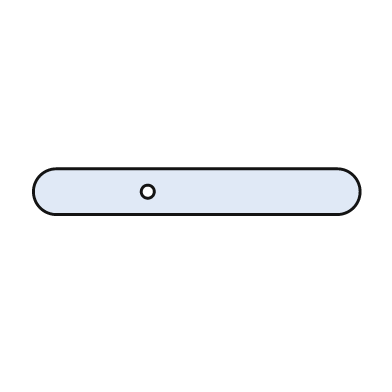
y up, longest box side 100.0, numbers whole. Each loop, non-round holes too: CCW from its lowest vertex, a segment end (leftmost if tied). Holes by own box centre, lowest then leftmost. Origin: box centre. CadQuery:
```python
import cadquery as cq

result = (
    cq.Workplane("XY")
    .moveTo(-43.0, -7.0)
    .lineTo(43.0, -7.0)
    .threePointArc((50.0, 0.0), (43.0, 7.0))
    .lineTo(-43.0, 7.0)
    .threePointArc((-50.0, 0.0), (-43.0, -7.0))
    .close()
    .moveTo(-15.0, 0.0)
    .circle(2.0)
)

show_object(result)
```